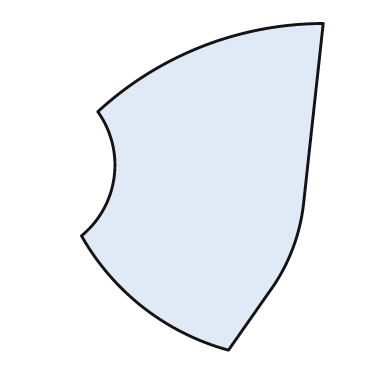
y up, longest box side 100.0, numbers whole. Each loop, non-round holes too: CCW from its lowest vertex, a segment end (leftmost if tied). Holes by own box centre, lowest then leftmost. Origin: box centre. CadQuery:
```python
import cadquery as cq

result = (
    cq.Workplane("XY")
    .moveTo(8.0, -50.0)
    .lineTo(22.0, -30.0)
    .threePointArc((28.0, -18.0), (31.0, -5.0))
    .lineTo(37.0, 50.0)
    .threePointArc((0.0, 43.0), (-32.0, 23.0))
    .threePointArc((-27.0, 3.0), (-37.0, -15.0))
    .threePointArc((-18.0, -37.0), (8.0, -50.0))
    .close()
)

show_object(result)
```